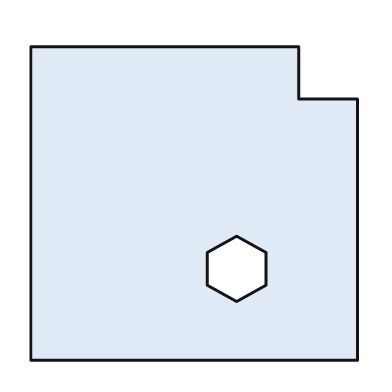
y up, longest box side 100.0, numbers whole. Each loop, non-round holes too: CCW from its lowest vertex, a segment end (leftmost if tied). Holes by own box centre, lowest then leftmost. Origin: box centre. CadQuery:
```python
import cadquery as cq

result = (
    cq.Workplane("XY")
    .moveTo(-50.0, -48.0)
    .lineTo(50.0, -48.0)
    .lineTo(50.0, 32.0)
    .lineTo(32.0, 32.0)
    .lineTo(32.0, 48.0)
    .lineTo(-50.0, 48.0)
    .close()
    .moveTo(13.0, -30.0)
    .lineTo(22.0, -25.0)
    .lineTo(22.0, -15.0)
    .lineTo(13.0, -10.0)
    .lineTo(4.0, -15.0)
    .lineTo(4.0, -25.0)
    .close()
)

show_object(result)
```